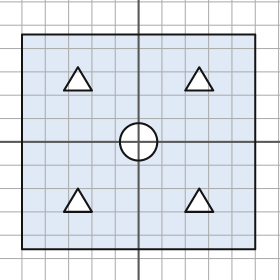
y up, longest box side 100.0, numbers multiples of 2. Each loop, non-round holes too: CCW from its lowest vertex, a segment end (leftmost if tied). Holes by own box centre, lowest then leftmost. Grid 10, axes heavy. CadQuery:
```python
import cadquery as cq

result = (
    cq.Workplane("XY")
    .moveTo(-50.0, -46.0)
    .lineTo(50.0, -46.0)
    .lineTo(50.0, 46.0)
    .lineTo(-50.0, 46.0)
    .close()
    .moveTo(-32.0, -30.0)
    .lineTo(-20.0, -30.0)
    .lineTo(-26.0, -20.0)
    .close()
    .moveTo(20.0, -30.0)
    .lineTo(32.0, -30.0)
    .lineTo(26.0, -20.0)
    .close()
    .moveTo(0.0, 0.0)
    .circle(8.0)
    .moveTo(-32.0, 22.0)
    .lineTo(-20.0, 22.0)
    .lineTo(-26.0, 32.0)
    .close()
    .moveTo(20.0, 22.0)
    .lineTo(32.0, 22.0)
    .lineTo(26.0, 32.0)
    .close()
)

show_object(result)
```